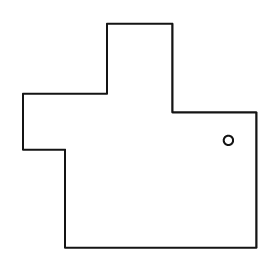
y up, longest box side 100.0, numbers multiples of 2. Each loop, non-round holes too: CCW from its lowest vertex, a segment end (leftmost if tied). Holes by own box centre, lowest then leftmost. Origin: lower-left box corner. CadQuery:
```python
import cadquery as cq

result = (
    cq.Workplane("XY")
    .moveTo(18.0, 0.0)
    .lineTo(100.0, 0.0)
    .lineTo(100.0, 58.0)
    .lineTo(64.0, 58.0)
    .lineTo(64.0, 96.0)
    .lineTo(36.0, 96.0)
    .lineTo(36.0, 66.0)
    .lineTo(0.0, 66.0)
    .lineTo(0.0, 42.0)
    .lineTo(18.0, 42.0)
    .close()
    .moveTo(88.0, 46.0)
    .circle(2.0)
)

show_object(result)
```